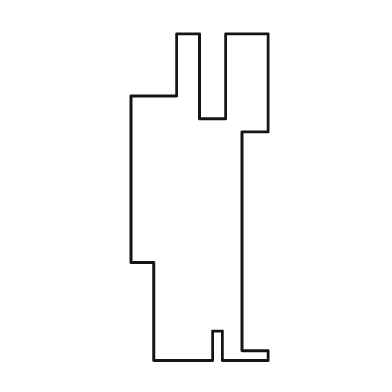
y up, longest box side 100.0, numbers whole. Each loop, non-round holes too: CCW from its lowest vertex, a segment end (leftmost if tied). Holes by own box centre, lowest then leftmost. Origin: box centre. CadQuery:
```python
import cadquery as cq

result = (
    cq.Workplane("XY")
    .moveTo(-14.0, -50.0)
    .lineTo(4.0, -50.0)
    .lineTo(4.0, -41.0)
    .lineTo(7.0, -41.0)
    .lineTo(7.0, -50.0)
    .lineTo(21.0, -50.0)
    .lineTo(21.0, -47.0)
    .lineTo(13.0, -47.0)
    .lineTo(13.0, 20.0)
    .lineTo(21.0, 20.0)
    .lineTo(21.0, 50.0)
    .lineTo(8.0, 50.0)
    .lineTo(8.0, 24.0)
    .lineTo(0.0, 24.0)
    .lineTo(0.0, 50.0)
    .lineTo(-7.0, 50.0)
    .lineTo(-7.0, 31.0)
    .lineTo(-21.0, 31.0)
    .lineTo(-21.0, -20.0)
    .lineTo(-14.0, -20.0)
    .close()
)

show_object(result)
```